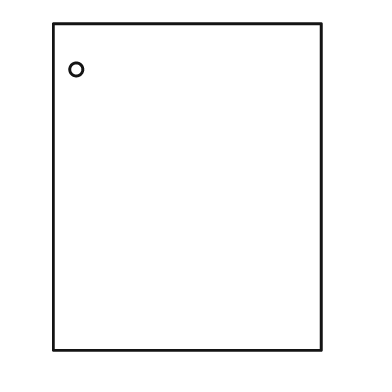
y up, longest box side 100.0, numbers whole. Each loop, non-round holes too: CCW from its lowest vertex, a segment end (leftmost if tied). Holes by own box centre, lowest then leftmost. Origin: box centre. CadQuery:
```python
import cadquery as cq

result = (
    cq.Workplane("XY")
    .moveTo(-41.0, -50.0)
    .lineTo(41.0, -50.0)
    .lineTo(41.0, 50.0)
    .lineTo(-41.0, 50.0)
    .close()
    .moveTo(-34.0, 36.0)
    .circle(2.0)
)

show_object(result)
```